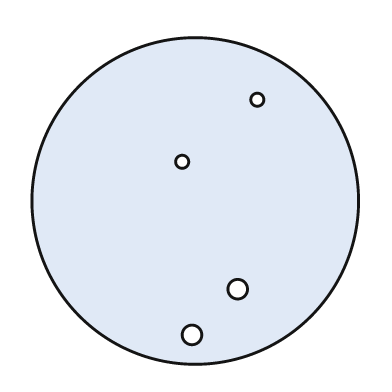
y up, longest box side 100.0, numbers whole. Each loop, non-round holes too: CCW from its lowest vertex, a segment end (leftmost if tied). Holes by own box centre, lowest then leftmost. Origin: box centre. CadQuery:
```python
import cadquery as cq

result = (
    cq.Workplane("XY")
    .moveTo(0.0, 0.0)
    .circle(50.0)
    .moveTo(-1.0, -41.0)
    .circle(3.0)
    .moveTo(13.0, -27.0)
    .circle(3.0)
    .moveTo(-4.0, 12.0)
    .circle(2.0)
    .moveTo(19.0, 31.0)
    .circle(2.0)
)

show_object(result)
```